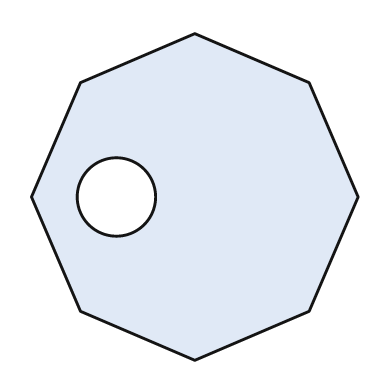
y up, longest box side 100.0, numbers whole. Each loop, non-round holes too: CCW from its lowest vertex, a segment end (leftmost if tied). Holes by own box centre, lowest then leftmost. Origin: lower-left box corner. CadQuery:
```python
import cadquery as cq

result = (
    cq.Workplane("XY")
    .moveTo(50.0, 0.0)
    .lineTo(85.0, 15.0)
    .lineTo(100.0, 50.0)
    .lineTo(85.0, 85.0)
    .lineTo(50.0, 100.0)
    .lineTo(15.0, 85.0)
    .lineTo(0.0, 50.0)
    .lineTo(15.0, 15.0)
    .close()
    .moveTo(26.0, 50.0)
    .circle(12.0)
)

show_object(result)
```